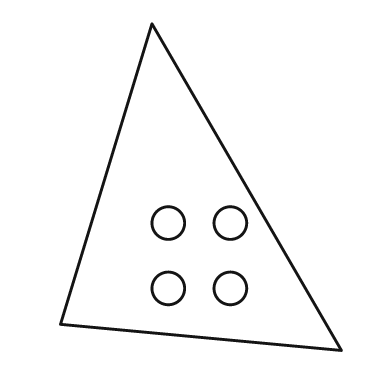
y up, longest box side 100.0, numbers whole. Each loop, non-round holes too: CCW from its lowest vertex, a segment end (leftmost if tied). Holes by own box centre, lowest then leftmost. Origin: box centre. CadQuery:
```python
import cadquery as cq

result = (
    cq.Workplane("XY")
    .moveTo(43.0, -50.0)
    .lineTo(-15.0, 50.0)
    .lineTo(-43.0, -42.0)
    .close()
    .moveTo(-10.0, -31.0)
    .circle(5.0)
    .moveTo(9.0, -31.0)
    .circle(5.0)
    .moveTo(-10.0, -11.0)
    .circle(5.0)
    .moveTo(9.0, -11.0)
    .circle(5.0)
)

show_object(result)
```